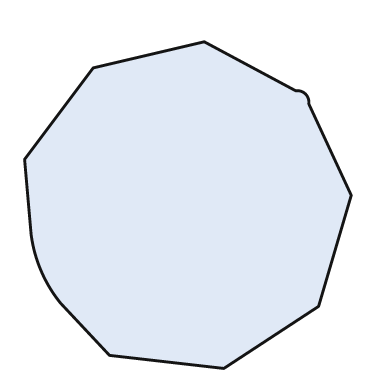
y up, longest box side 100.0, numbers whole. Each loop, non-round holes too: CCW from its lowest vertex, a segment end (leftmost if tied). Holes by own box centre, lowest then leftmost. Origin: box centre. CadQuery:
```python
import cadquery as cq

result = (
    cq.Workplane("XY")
    .moveTo(11.0, -50.0)
    .lineTo(40.0, -31.0)
    .lineTo(50.0, 3.0)
    .lineTo(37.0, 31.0)
    .threePointArc((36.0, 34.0), (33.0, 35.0))
    .lineTo(5.0, 50.0)
    .lineTo(-29.0, 42.0)
    .lineTo(-50.0, 14.0)
    .lineTo(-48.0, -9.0)
    .threePointArc((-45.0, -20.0), (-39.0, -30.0))
    .lineTo(-24.0, -46.0)
    .close()
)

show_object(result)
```